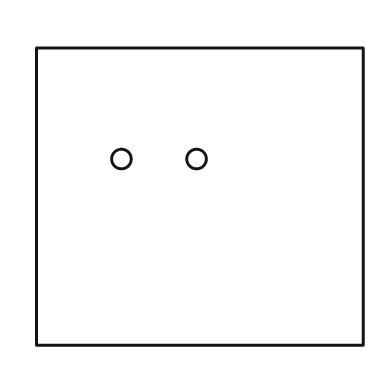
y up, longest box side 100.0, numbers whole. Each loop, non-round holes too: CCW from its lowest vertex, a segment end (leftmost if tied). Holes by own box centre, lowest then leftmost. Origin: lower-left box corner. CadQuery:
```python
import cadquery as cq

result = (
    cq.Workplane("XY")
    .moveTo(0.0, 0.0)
    .lineTo(100.0, 0.0)
    .lineTo(100.0, 91.0)
    .lineTo(0.0, 91.0)
    .close()
    .moveTo(26.0, 57.0)
    .circle(3.0)
    .moveTo(49.0, 57.0)
    .circle(3.0)
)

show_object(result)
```